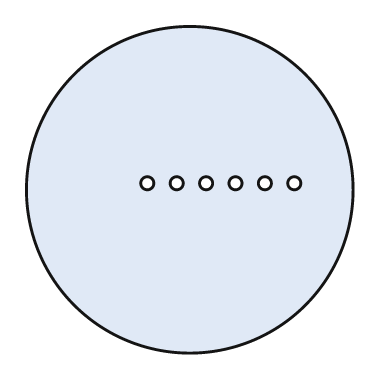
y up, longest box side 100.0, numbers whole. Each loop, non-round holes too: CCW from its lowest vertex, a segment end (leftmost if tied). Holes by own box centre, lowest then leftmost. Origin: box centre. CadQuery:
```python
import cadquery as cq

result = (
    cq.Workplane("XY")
    .moveTo(0.0, 0.0)
    .circle(50.0)
    .moveTo(-13.0, 2.0)
    .circle(2.0)
    .moveTo(-4.0, 2.0)
    .circle(2.0)
    .moveTo(5.0, 2.0)
    .circle(2.0)
    .moveTo(14.0, 2.0)
    .circle(2.0)
    .moveTo(23.0, 2.0)
    .circle(2.0)
    .moveTo(32.0, 2.0)
    .circle(2.0)
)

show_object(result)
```